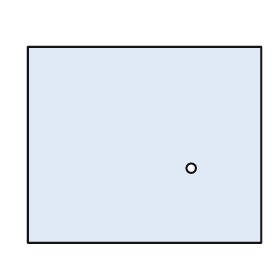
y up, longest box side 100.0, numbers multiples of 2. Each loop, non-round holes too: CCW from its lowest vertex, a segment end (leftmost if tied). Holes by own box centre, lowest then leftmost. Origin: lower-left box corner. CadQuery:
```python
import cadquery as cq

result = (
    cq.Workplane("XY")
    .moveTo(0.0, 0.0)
    .lineTo(100.0, 0.0)
    .lineTo(100.0, 84.0)
    .lineTo(0.0, 84.0)
    .close()
    .moveTo(70.0, 32.0)
    .circle(2.0)
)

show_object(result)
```